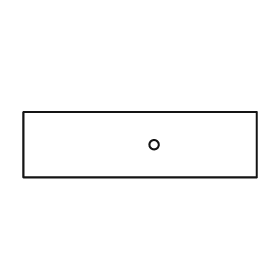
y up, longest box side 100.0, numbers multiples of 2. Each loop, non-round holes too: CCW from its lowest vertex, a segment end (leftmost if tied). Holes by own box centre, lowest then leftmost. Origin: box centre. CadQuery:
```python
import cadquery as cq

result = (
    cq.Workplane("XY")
    .moveTo(-50.0, -14.0)
    .lineTo(50.0, -14.0)
    .lineTo(50.0, 14.0)
    .lineTo(-50.0, 14.0)
    .close()
    .moveTo(6.0, 0.0)
    .circle(2.0)
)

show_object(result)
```